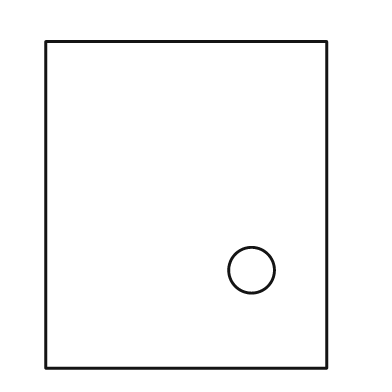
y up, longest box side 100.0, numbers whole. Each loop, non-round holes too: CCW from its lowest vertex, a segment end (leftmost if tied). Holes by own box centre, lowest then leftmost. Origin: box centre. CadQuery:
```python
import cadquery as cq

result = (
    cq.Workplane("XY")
    .moveTo(-43.0, -50.0)
    .lineTo(43.0, -50.0)
    .lineTo(43.0, 50.0)
    .lineTo(-43.0, 50.0)
    .close()
    .moveTo(20.0, -20.0)
    .circle(7.0)
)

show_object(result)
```